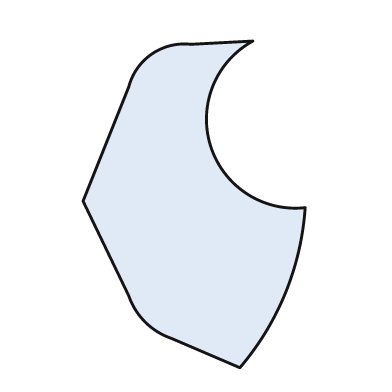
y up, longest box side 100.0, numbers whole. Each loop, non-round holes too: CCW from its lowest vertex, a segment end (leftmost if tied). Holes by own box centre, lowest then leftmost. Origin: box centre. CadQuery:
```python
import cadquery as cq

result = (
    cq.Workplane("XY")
    .moveTo(14.0, -50.0)
    .threePointArc((28.0, -27.0), (34.0, -1.0))
    .threePointArc((5.0, 18.0), (18.0, 50.0))
    .lineTo(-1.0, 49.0)
    .threePointArc((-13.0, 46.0), (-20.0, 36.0))
    .lineTo(-34.0, 1.0)
    .lineTo(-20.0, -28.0)
    .threePointArc((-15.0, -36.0), (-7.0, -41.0))
    .close()
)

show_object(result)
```